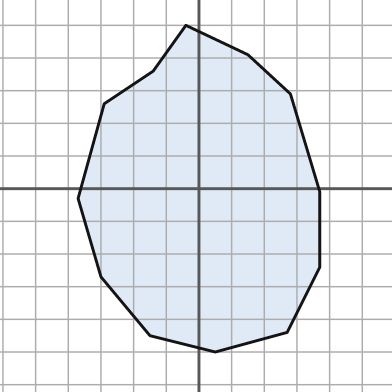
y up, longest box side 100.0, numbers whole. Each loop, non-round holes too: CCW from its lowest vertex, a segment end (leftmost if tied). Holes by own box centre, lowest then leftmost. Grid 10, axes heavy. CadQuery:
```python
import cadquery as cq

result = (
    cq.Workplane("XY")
    .moveTo(5.0, -50.0)
    .lineTo(27.0, -44.0)
    .lineTo(37.0, -24.0)
    .lineTo(37.0, -1.0)
    .lineTo(28.0, 29.0)
    .lineTo(15.0, 41.0)
    .lineTo(-4.0, 50.0)
    .lineTo(-14.0, 36.0)
    .lineTo(-29.0, 26.0)
    .lineTo(-37.0, -3.0)
    .lineTo(-30.0, -27.0)
    .lineTo(-15.0, -45.0)
    .close()
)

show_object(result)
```